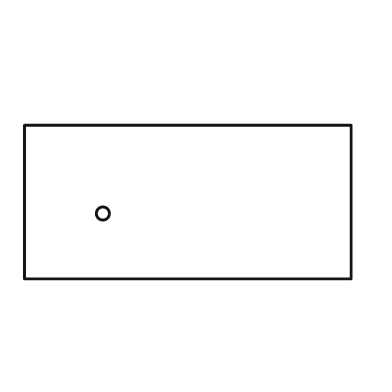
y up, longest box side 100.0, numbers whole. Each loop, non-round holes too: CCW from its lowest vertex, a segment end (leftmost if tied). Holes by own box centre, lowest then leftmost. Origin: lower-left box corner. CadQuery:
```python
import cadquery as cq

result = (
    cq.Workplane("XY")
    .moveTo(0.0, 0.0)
    .lineTo(100.0, 0.0)
    .lineTo(100.0, 47.0)
    .lineTo(0.0, 47.0)
    .close()
    .moveTo(24.0, 20.0)
    .circle(2.0)
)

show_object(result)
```